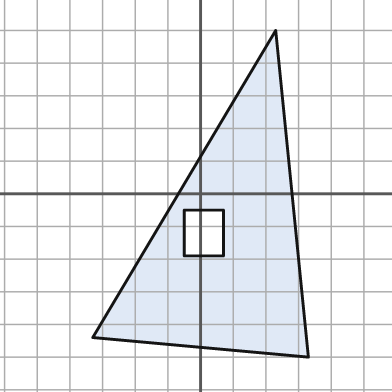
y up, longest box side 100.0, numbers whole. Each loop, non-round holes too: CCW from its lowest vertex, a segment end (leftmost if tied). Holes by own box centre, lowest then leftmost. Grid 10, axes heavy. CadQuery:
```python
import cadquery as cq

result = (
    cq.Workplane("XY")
    .moveTo(33.0, -50.0)
    .lineTo(23.0, 50.0)
    .lineTo(-33.0, -44.0)
    .close()
    .moveTo(-5.0, -19.0)
    .lineTo(7.0, -19.0)
    .lineTo(7.0, -5.0)
    .lineTo(-5.0, -5.0)
    .close()
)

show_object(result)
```